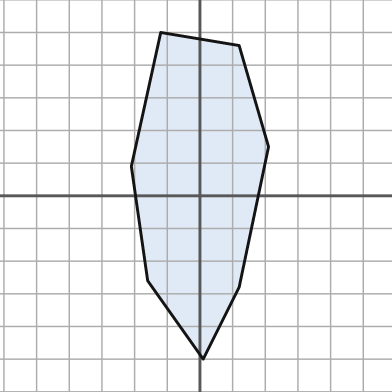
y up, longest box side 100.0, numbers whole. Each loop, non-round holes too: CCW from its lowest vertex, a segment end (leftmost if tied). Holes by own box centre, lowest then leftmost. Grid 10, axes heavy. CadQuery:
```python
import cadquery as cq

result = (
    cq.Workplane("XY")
    .moveTo(1.0, -50.0)
    .lineTo(12.0, -28.0)
    .lineTo(21.0, 15.0)
    .lineTo(12.0, 46.0)
    .lineTo(-12.0, 50.0)
    .lineTo(-21.0, 9.0)
    .lineTo(-16.0, -26.0)
    .close()
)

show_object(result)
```